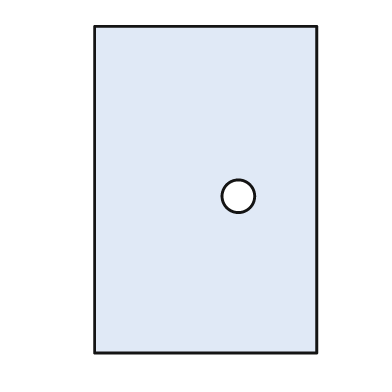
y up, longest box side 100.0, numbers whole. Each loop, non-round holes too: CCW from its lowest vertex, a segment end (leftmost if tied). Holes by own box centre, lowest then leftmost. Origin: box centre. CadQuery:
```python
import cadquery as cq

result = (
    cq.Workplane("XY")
    .moveTo(-34.0, -50.0)
    .lineTo(34.0, -50.0)
    .lineTo(34.0, 50.0)
    .lineTo(-34.0, 50.0)
    .close()
    .moveTo(10.0, -2.0)
    .circle(5.0)
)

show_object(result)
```